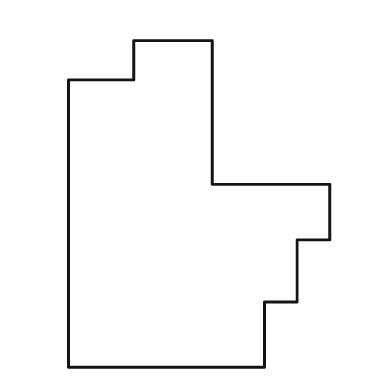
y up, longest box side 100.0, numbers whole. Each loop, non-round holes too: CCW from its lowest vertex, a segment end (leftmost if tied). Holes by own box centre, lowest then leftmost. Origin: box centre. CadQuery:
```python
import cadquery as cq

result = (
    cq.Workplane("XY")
    .moveTo(-40.0, -50.0)
    .lineTo(20.0, -50.0)
    .lineTo(20.0, -30.0)
    .lineTo(30.0, -30.0)
    .lineTo(30.0, -11.0)
    .lineTo(40.0, -11.0)
    .lineTo(40.0, 6.0)
    .lineTo(4.0, 6.0)
    .lineTo(4.0, 50.0)
    .lineTo(-20.0, 50.0)
    .lineTo(-20.0, 38.0)
    .lineTo(-40.0, 38.0)
    .close()
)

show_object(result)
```